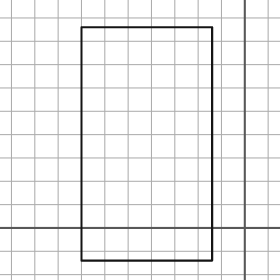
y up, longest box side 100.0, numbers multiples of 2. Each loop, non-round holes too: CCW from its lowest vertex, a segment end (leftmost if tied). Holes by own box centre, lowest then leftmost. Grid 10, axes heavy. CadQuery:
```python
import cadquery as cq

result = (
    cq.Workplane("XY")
    .moveTo(-70.0, -14.0)
    .lineTo(-14.0, -14.0)
    .lineTo(-14.0, 86.0)
    .lineTo(-70.0, 86.0)
    .close()
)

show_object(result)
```